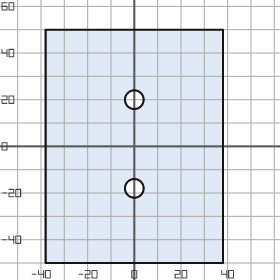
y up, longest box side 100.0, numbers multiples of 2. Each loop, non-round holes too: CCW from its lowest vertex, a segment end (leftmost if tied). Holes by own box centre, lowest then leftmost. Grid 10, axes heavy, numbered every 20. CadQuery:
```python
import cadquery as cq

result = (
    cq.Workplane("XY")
    .moveTo(-38.0, -50.0)
    .lineTo(38.0, -50.0)
    .lineTo(38.0, 50.0)
    .lineTo(-38.0, 50.0)
    .close()
    .moveTo(0.0, -18.0)
    .circle(4.0)
    .moveTo(0.0, 20.0)
    .circle(4.0)
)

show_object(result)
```